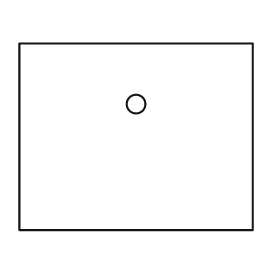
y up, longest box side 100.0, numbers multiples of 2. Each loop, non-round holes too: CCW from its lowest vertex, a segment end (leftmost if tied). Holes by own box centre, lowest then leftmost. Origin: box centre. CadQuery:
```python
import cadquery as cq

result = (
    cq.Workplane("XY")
    .moveTo(-50.0, -40.0)
    .lineTo(50.0, -40.0)
    .lineTo(50.0, 40.0)
    .lineTo(-50.0, 40.0)
    .close()
    .moveTo(0.0, 14.0)
    .circle(4.0)
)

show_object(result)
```